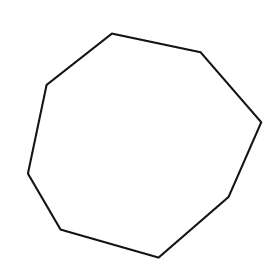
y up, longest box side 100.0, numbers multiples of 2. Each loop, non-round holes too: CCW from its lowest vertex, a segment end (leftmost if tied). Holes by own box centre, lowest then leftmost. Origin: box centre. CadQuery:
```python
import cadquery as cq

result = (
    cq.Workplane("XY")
    .moveTo(6.0, -48.0)
    .lineTo(36.0, -22.0)
    .lineTo(50.0, 10.0)
    .lineTo(24.0, 40.0)
    .lineTo(-14.0, 48.0)
    .lineTo(-42.0, 26.0)
    .lineTo(-50.0, -12.0)
    .lineTo(-36.0, -36.0)
    .close()
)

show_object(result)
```